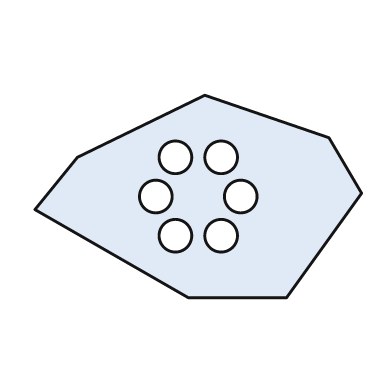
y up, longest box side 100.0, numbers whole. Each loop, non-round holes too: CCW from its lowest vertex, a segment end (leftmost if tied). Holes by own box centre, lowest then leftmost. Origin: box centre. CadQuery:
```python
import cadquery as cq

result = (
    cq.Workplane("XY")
    .moveTo(-3.0, -31.0)
    .lineTo(27.0, -31.0)
    .lineTo(50.0, 1.0)
    .lineTo(40.0, 18.0)
    .lineTo(2.0, 31.0)
    .lineTo(-37.0, 12.0)
    .lineTo(-50.0, -4.0)
    .close()
    .moveTo(-7.0, -12.0)
    .circle(5.0)
    .moveTo(7.0, -12.0)
    .circle(5.0)
    .moveTo(-13.0, 0.0)
    .circle(5.0)
    .moveTo(13.0, 0.0)
    .circle(5.0)
    .moveTo(-7.0, 12.0)
    .circle(5.0)
    .moveTo(7.0, 12.0)
    .circle(5.0)
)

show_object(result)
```